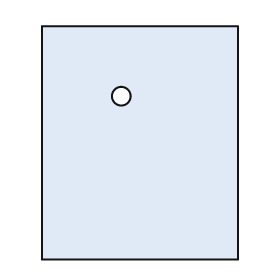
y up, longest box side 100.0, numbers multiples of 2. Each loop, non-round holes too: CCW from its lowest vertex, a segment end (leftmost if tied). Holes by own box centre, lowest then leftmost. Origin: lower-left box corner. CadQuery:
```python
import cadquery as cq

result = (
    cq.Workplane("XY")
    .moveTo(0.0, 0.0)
    .lineTo(84.0, 0.0)
    .lineTo(84.0, 100.0)
    .lineTo(0.0, 100.0)
    .close()
    .moveTo(34.0, 70.0)
    .circle(4.0)
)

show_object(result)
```